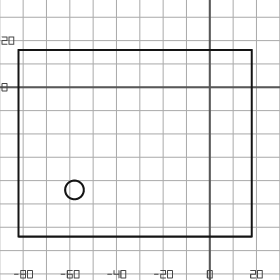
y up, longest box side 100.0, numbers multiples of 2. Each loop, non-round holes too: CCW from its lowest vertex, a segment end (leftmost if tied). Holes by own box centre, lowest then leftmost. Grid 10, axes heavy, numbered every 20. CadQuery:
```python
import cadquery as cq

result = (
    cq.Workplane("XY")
    .moveTo(-82.0, -64.0)
    .lineTo(18.0, -64.0)
    .lineTo(18.0, 16.0)
    .lineTo(-82.0, 16.0)
    .close()
    .moveTo(-58.0, -44.0)
    .circle(4.0)
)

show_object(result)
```